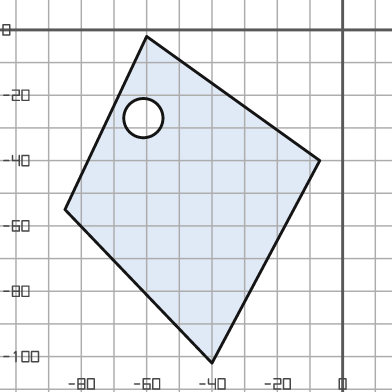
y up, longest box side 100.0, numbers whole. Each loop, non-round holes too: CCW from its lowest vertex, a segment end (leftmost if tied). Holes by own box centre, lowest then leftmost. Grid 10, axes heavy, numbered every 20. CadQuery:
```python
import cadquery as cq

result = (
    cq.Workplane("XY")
    .moveTo(-40.0, -102.0)
    .lineTo(-7.0, -40.0)
    .lineTo(-60.0, -2.0)
    .lineTo(-85.0, -55.0)
    .close()
    .moveTo(-61.0, -27.0)
    .circle(6.0)
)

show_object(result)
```